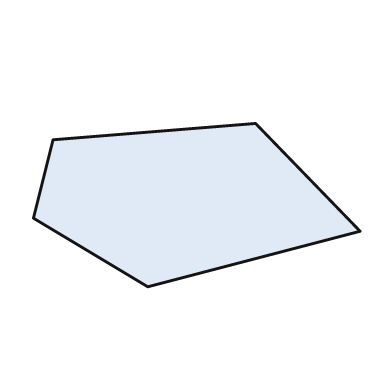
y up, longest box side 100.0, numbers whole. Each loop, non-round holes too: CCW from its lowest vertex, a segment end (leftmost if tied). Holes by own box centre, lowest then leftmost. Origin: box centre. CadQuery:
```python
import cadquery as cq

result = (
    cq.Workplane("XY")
    .moveTo(-15.0, -25.0)
    .lineTo(50.0, -8.0)
    .lineTo(18.0, 25.0)
    .lineTo(-44.0, 20.0)
    .lineTo(-50.0, -4.0)
    .close()
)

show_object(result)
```